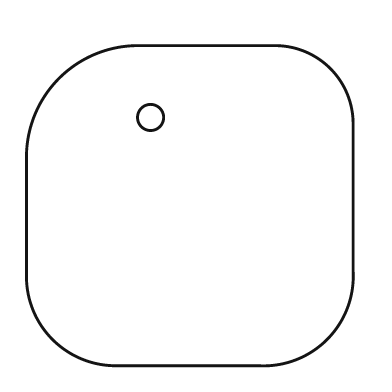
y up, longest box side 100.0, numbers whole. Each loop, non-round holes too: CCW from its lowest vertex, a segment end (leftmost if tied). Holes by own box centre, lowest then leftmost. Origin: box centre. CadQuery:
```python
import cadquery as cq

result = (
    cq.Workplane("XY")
    .moveTo(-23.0, -49.0)
    .lineTo(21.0, -49.0)
    .threePointArc((42.0, -41.0), (50.0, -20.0))
    .lineTo(50.0, 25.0)
    .threePointArc((43.0, 42.0), (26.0, 49.0))
    .lineTo(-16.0, 49.0)
    .threePointArc((-40.0, 39.0), (-50.0, 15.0))
    .lineTo(-50.0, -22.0)
    .threePointArc((-42.0, -41.0), (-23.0, -49.0))
    .close()
    .moveTo(-12.0, 27.0)
    .circle(4.0)
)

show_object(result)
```